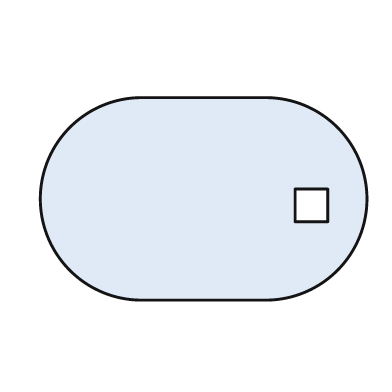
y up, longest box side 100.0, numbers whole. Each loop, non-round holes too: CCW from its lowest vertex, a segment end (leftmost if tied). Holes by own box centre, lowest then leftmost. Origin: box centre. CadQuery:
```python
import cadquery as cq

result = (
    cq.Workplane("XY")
    .moveTo(-19.0, -31.0)
    .lineTo(19.0, -31.0)
    .threePointArc((50.0, 0.0), (19.0, 31.0))
    .lineTo(-19.0, 31.0)
    .threePointArc((-50.0, 0.0), (-19.0, -31.0))
    .close()
    .moveTo(28.0, -7.0)
    .lineTo(38.0, -7.0)
    .lineTo(38.0, 3.0)
    .lineTo(28.0, 3.0)
    .close()
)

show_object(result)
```